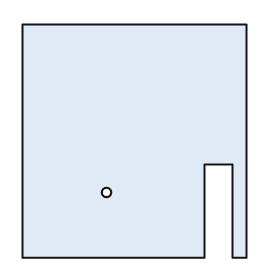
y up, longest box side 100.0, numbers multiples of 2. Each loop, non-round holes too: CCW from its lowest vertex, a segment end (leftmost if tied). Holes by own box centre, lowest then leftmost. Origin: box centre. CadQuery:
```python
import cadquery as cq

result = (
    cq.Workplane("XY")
    .moveTo(-48.0, -50.0)
    .lineTo(30.0, -50.0)
    .lineTo(30.0, -10.0)
    .lineTo(42.0, -10.0)
    .lineTo(42.0, -50.0)
    .lineTo(48.0, -50.0)
    .lineTo(48.0, 50.0)
    .lineTo(-48.0, 50.0)
    .close()
    .moveTo(-12.0, -22.0)
    .circle(2.0)
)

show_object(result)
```